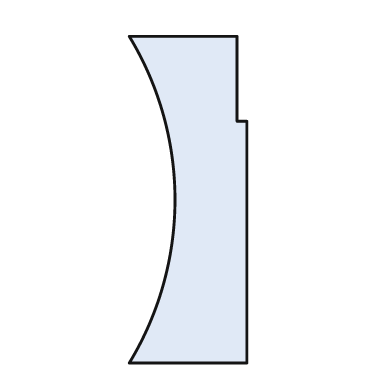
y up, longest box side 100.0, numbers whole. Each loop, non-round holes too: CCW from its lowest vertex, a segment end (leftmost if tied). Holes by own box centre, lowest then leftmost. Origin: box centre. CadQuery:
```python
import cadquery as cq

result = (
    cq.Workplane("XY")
    .moveTo(-18.0, -50.0)
    .lineTo(18.0, -50.0)
    .lineTo(18.0, 24.0)
    .lineTo(15.0, 24.0)
    .lineTo(15.0, 50.0)
    .lineTo(-18.0, 50.0)
    .threePointArc((-4.0, 0.0), (-18.0, -50.0))
    .close()
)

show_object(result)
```